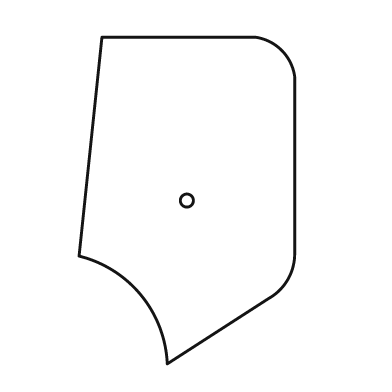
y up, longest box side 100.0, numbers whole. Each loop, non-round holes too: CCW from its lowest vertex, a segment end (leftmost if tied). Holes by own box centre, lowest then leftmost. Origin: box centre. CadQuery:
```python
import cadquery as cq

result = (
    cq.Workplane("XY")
    .moveTo(-6.0, -50.0)
    .lineTo(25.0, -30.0)
    .threePointArc((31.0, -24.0), (33.0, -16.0))
    .lineTo(33.0, 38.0)
    .threePointArc((29.0, 46.0), (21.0, 50.0))
    .lineTo(-26.0, 50.0)
    .lineTo(-33.0, -17.0)
    .threePointArc((-14.0, -29.0), (-6.0, -50.0))
    .close()
    .moveTo(0.0, 0.0)
    .circle(2.0)
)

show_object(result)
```